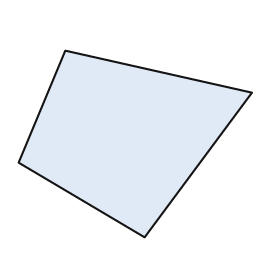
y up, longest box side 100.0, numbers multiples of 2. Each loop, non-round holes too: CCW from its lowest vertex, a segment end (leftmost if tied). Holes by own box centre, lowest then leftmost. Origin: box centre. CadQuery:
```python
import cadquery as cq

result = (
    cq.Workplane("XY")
    .moveTo(4.0, -40.0)
    .lineTo(50.0, 22.0)
    .lineTo(-30.0, 40.0)
    .lineTo(-50.0, -8.0)
    .close()
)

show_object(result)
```